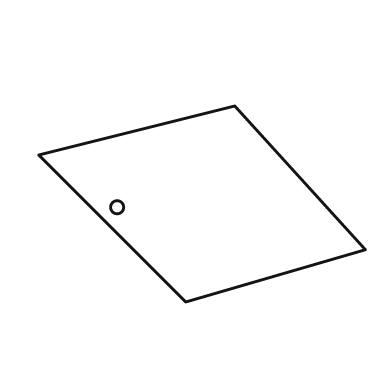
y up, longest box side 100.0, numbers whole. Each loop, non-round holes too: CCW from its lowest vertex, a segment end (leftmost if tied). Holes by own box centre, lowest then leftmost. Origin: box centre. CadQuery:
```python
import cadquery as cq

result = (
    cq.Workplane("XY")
    .moveTo(-5.0, -30.0)
    .lineTo(50.0, -14.0)
    .lineTo(10.0, 30.0)
    .lineTo(-50.0, 15.0)
    .close()
    .moveTo(-26.0, -1.0)
    .circle(2.0)
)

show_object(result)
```